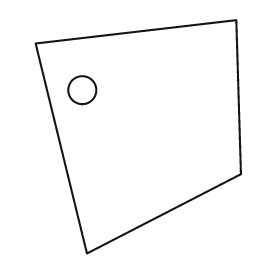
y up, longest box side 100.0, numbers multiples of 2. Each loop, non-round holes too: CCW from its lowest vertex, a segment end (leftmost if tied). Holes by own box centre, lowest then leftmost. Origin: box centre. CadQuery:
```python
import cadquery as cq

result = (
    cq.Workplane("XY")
    .moveTo(-22.0, -50.0)
    .lineTo(44.0, -16.0)
    .lineTo(42.0, 50.0)
    .lineTo(-44.0, 40.0)
    .close()
    .moveTo(-24.0, 20.0)
    .circle(6.0)
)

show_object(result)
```